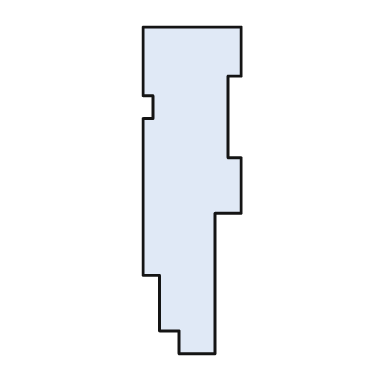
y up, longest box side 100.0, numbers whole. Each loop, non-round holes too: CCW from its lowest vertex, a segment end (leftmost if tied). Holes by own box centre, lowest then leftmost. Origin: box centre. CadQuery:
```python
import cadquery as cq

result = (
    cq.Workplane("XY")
    .moveTo(-4.0, -50.0)
    .lineTo(7.0, -50.0)
    .lineTo(7.0, -7.0)
    .lineTo(15.0, -7.0)
    .lineTo(15.0, 10.0)
    .lineTo(11.0, 10.0)
    .lineTo(11.0, 35.0)
    .lineTo(15.0, 35.0)
    .lineTo(15.0, 50.0)
    .lineTo(-15.0, 50.0)
    .lineTo(-15.0, 29.0)
    .lineTo(-12.0, 29.0)
    .lineTo(-12.0, 22.0)
    .lineTo(-15.0, 22.0)
    .lineTo(-15.0, -26.0)
    .lineTo(-10.0, -26.0)
    .lineTo(-10.0, -43.0)
    .lineTo(-4.0, -43.0)
    .close()
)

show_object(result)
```